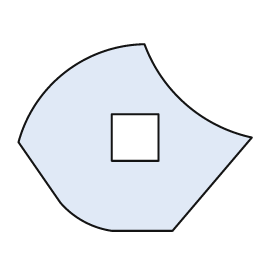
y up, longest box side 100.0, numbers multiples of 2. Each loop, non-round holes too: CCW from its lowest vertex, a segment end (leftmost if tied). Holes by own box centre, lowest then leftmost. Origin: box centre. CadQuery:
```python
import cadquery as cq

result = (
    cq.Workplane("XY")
    .moveTo(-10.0, -40.0)
    .lineTo(16.0, -40.0)
    .lineTo(50.0, 0.0)
    .threePointArc((22.0, 14.0), (4.0, 40.0))
    .threePointArc((-30.0, 28.0), (-50.0, -2.0))
    .lineTo(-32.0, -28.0)
    .threePointArc((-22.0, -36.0), (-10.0, -40.0))
    .close()
    .moveTo(-10.0, -10.0)
    .lineTo(10.0, -10.0)
    .lineTo(10.0, 10.0)
    .lineTo(-10.0, 10.0)
    .close()
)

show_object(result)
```